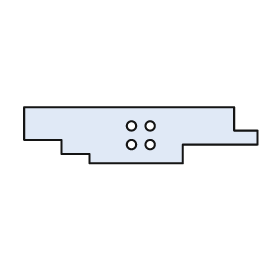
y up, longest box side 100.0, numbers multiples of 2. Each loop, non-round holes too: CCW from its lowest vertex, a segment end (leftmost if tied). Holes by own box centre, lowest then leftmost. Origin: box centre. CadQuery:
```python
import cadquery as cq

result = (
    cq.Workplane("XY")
    .moveTo(-22.0, -12.0)
    .lineTo(18.0, -12.0)
    .lineTo(18.0, -4.0)
    .lineTo(50.0, -4.0)
    .lineTo(50.0, 2.0)
    .lineTo(40.0, 2.0)
    .lineTo(40.0, 12.0)
    .lineTo(-50.0, 12.0)
    .lineTo(-50.0, -2.0)
    .lineTo(-34.0, -2.0)
    .lineTo(-34.0, -8.0)
    .lineTo(-22.0, -8.0)
    .close()
    .moveTo(-4.0, -4.0)
    .circle(2.0)
    .moveTo(4.0, -4.0)
    .circle(2.0)
    .moveTo(-4.0, 4.0)
    .circle(2.0)
    .moveTo(4.0, 4.0)
    .circle(2.0)
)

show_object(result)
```